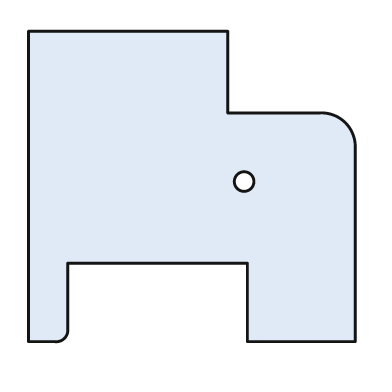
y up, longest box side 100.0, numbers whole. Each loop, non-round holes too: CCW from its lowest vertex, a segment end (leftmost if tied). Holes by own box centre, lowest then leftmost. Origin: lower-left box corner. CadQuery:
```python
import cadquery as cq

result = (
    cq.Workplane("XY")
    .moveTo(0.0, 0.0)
    .lineTo(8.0, 0.0)
    .threePointArc((11.0, 1.0), (12.0, 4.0))
    .lineTo(12.0, 24.0)
    .lineTo(67.0, 24.0)
    .lineTo(67.0, 0.0)
    .lineTo(100.0, 0.0)
    .lineTo(100.0, 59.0)
    .threePointArc((97.0, 67.0), (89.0, 70.0))
    .lineTo(61.0, 70.0)
    .lineTo(61.0, 95.0)
    .lineTo(0.0, 95.0)
    .close()
    .moveTo(66.0, 49.0)
    .circle(3.0)
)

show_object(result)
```